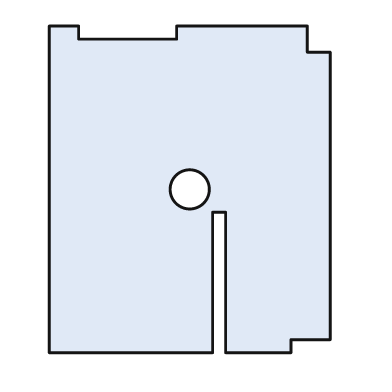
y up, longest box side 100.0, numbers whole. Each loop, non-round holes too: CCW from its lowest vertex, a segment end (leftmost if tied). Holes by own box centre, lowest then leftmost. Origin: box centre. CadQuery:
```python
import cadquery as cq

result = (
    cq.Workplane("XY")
    .moveTo(-43.0, -50.0)
    .lineTo(7.0, -50.0)
    .lineTo(7.0, -7.0)
    .lineTo(11.0, -7.0)
    .lineTo(11.0, -50.0)
    .lineTo(31.0, -50.0)
    .lineTo(31.0, -46.0)
    .lineTo(43.0, -46.0)
    .lineTo(43.0, 42.0)
    .lineTo(36.0, 42.0)
    .lineTo(36.0, 50.0)
    .lineTo(-4.0, 50.0)
    .lineTo(-4.0, 46.0)
    .lineTo(-34.0, 46.0)
    .lineTo(-34.0, 50.0)
    .lineTo(-43.0, 50.0)
    .close()
    .moveTo(0.0, 0.0)
    .circle(6.0)
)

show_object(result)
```